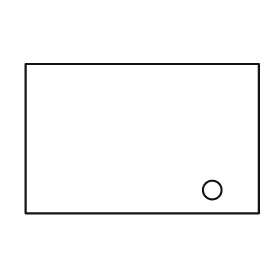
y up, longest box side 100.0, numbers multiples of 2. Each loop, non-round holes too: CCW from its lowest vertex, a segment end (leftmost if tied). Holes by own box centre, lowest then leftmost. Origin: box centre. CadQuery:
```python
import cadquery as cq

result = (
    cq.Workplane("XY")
    .moveTo(-50.0, -32.0)
    .lineTo(50.0, -32.0)
    .lineTo(50.0, 32.0)
    .lineTo(-50.0, 32.0)
    .close()
    .moveTo(30.0, -22.0)
    .circle(4.0)
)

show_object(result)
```